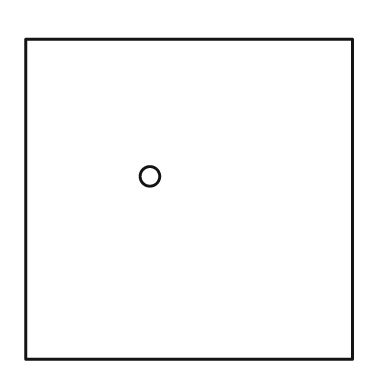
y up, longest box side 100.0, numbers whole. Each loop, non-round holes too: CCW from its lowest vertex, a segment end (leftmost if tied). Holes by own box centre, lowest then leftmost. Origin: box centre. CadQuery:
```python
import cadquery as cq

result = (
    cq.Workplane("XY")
    .moveTo(-50.0, -49.0)
    .lineTo(50.0, -49.0)
    .lineTo(50.0, 49.0)
    .lineTo(-50.0, 49.0)
    .close()
    .moveTo(-12.0, 7.0)
    .circle(3.0)
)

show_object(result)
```